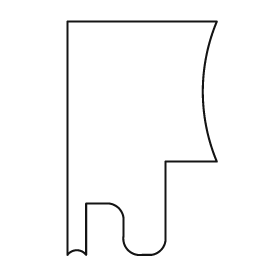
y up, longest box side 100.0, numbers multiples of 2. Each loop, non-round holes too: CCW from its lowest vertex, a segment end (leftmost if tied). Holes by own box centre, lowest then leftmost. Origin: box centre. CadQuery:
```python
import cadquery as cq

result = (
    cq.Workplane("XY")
    .moveTo(-32.0, -50.0)
    .threePointArc((-28.0, -48.0), (-24.0, -50.0))
    .lineTo(-24.0, -28.0)
    .lineTo(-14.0, -28.0)
    .threePointArc((-10.0, -30.0), (-8.0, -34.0))
    .lineTo(-8.0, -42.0)
    .threePointArc((-6.0, -48.0), (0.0, -50.0))
    .lineTo(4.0, -50.0)
    .threePointArc((8.0, -48.0), (10.0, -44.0))
    .lineTo(10.0, -10.0)
    .lineTo(32.0, -10.0)
    .threePointArc((26.0, 20.0), (32.0, 50.0))
    .lineTo(-32.0, 50.0)
    .close()
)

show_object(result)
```